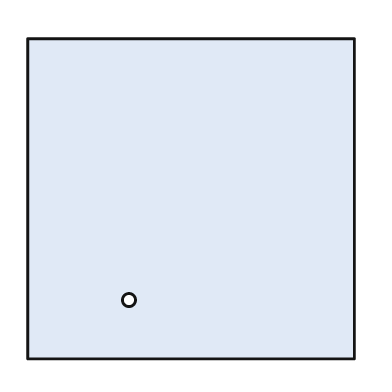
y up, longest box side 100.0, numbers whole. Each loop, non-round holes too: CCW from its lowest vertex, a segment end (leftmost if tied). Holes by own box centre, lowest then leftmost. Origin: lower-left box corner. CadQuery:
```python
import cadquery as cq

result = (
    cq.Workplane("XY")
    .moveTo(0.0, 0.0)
    .lineTo(100.0, 0.0)
    .lineTo(100.0, 98.0)
    .lineTo(0.0, 98.0)
    .close()
    .moveTo(31.0, 18.0)
    .circle(2.0)
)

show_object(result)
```